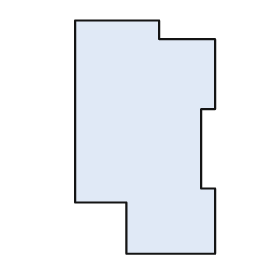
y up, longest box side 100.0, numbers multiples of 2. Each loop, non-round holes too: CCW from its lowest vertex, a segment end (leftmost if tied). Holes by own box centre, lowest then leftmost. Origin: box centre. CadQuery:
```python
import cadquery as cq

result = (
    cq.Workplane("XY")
    .moveTo(-8.0, -50.0)
    .lineTo(30.0, -50.0)
    .lineTo(30.0, -22.0)
    .lineTo(24.0, -22.0)
    .lineTo(24.0, 12.0)
    .lineTo(30.0, 12.0)
    .lineTo(30.0, 42.0)
    .lineTo(6.0, 42.0)
    .lineTo(6.0, 50.0)
    .lineTo(-30.0, 50.0)
    .lineTo(-30.0, -28.0)
    .lineTo(-8.0, -28.0)
    .close()
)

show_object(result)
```